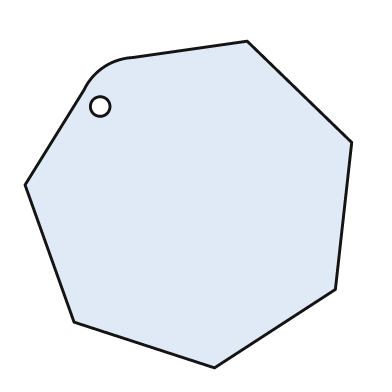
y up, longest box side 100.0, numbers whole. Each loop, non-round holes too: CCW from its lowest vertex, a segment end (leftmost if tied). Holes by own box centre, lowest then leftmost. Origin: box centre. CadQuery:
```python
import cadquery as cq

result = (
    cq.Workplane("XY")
    .moveTo(8.0, -50.0)
    .lineTo(45.0, -26.0)
    .lineTo(50.0, 19.0)
    .lineTo(18.0, 50.0)
    .lineTo(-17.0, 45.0)
    .threePointArc((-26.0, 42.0), (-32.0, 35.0))
    .lineTo(-50.0, 6.0)
    .lineTo(-35.0, -36.0)
    .close()
    .moveTo(-27.0, 30.0)
    .circle(3.0)
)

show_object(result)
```